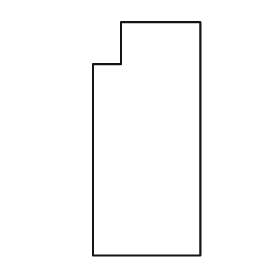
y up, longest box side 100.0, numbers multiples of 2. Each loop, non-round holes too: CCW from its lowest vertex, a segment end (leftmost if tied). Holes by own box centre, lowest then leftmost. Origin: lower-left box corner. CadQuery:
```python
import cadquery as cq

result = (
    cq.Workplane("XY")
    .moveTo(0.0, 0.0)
    .lineTo(46.0, 0.0)
    .lineTo(46.0, 100.0)
    .lineTo(12.0, 100.0)
    .lineTo(12.0, 82.0)
    .lineTo(0.0, 82.0)
    .close()
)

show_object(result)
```